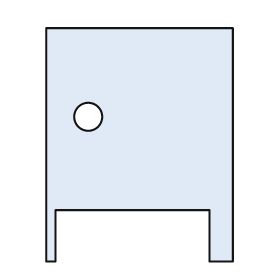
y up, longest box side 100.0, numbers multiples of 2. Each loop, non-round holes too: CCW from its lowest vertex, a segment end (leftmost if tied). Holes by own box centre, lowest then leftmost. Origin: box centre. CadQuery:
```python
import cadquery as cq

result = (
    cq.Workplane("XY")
    .moveTo(-40.0, -50.0)
    .lineTo(-36.0, -50.0)
    .lineTo(-36.0, -28.0)
    .lineTo(30.0, -28.0)
    .lineTo(30.0, -50.0)
    .lineTo(40.0, -50.0)
    .lineTo(40.0, 50.0)
    .lineTo(-40.0, 50.0)
    .close()
    .moveTo(-22.0, 12.0)
    .circle(6.0)
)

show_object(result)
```